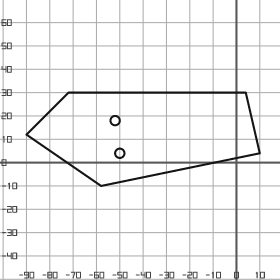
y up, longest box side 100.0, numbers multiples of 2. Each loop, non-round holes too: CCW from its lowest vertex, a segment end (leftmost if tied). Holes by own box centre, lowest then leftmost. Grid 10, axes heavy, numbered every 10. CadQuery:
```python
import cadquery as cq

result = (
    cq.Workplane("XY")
    .moveTo(-58.0, -10.0)
    .lineTo(10.0, 4.0)
    .lineTo(4.0, 30.0)
    .lineTo(-72.0, 30.0)
    .lineTo(-90.0, 12.0)
    .close()
    .moveTo(-50.0, 4.0)
    .circle(2.0)
    .moveTo(-52.0, 18.0)
    .circle(2.0)
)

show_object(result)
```